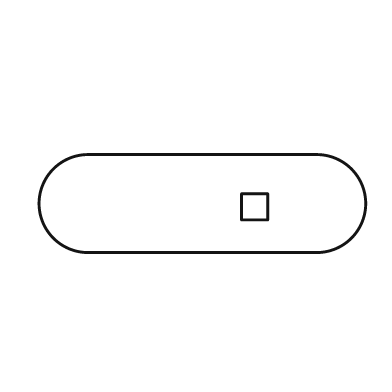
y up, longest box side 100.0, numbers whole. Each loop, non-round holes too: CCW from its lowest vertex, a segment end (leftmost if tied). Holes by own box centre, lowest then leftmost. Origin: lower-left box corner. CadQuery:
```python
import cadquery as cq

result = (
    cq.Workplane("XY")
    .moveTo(15.0, 0.0)
    .lineTo(85.0, 0.0)
    .threePointArc((100.0, 15.0), (85.0, 30.0))
    .lineTo(15.0, 30.0)
    .threePointArc((0.0, 15.0), (15.0, 0.0))
    .close()
    .moveTo(62.0, 10.0)
    .lineTo(70.0, 10.0)
    .lineTo(70.0, 18.0)
    .lineTo(62.0, 18.0)
    .close()
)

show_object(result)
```